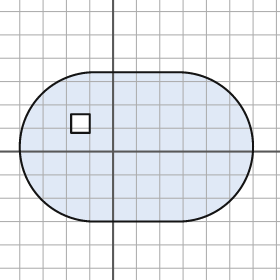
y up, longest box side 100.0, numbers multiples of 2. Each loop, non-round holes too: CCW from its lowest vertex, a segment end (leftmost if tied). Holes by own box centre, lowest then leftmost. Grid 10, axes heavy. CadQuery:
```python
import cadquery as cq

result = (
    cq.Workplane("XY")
    .moveTo(-8.0, -30.0)
    .lineTo(28.0, -30.0)
    .threePointArc((60.0, 2.0), (28.0, 34.0))
    .lineTo(-8.0, 34.0)
    .threePointArc((-40.0, 2.0), (-8.0, -30.0))
    .close()
    .moveTo(-18.0, 8.0)
    .lineTo(-10.0, 8.0)
    .lineTo(-10.0, 16.0)
    .lineTo(-18.0, 16.0)
    .close()
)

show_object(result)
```